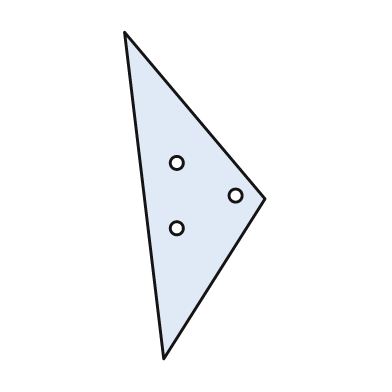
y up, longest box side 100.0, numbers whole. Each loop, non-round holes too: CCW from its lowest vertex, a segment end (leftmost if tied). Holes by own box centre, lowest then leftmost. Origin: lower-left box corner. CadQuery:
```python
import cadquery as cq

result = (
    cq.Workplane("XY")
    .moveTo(12.0, 0.0)
    .lineTo(43.0, 49.0)
    .lineTo(0.0, 100.0)
    .close()
    .moveTo(16.0, 40.0)
    .circle(2.0)
    .moveTo(34.0, 50.0)
    .circle(2.0)
    .moveTo(16.0, 60.0)
    .circle(2.0)
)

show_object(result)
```